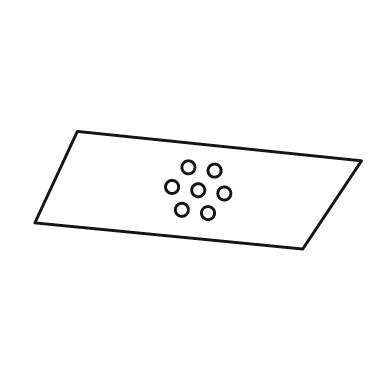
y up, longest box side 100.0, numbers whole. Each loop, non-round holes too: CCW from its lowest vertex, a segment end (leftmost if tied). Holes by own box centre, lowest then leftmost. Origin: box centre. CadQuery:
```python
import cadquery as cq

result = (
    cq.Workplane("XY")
    .moveTo(32.0, -18.0)
    .lineTo(50.0, 9.0)
    .lineTo(-37.0, 18.0)
    .lineTo(-50.0, -10.0)
    .close()
    .moveTo(3.0, -7.0)
    .circle(2.0)
    .moveTo(-5.0, -6.0)
    .circle(2.0)
    .moveTo(8.0, -1.0)
    .circle(2.0)
    .moveTo(0.0, 0.0)
    .circle(2.0)
    .moveTo(-8.0, 1.0)
    .circle(2.0)
    .moveTo(5.0, 6.0)
    .circle(2.0)
    .moveTo(-3.0, 7.0)
    .circle(2.0)
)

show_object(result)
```